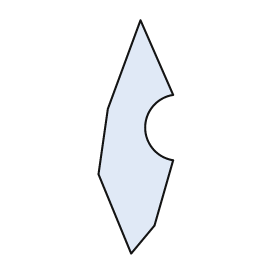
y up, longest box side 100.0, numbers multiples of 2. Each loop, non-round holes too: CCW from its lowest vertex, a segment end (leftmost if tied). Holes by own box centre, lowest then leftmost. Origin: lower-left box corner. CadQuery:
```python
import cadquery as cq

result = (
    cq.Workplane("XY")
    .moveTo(14.0, 0.0)
    .lineTo(24.0, 12.0)
    .lineTo(32.0, 40.0)
    .threePointArc((20.0, 54.0), (32.0, 68.0))
    .lineTo(18.0, 100.0)
    .lineTo(4.0, 62.0)
    .lineTo(0.0, 34.0)
    .close()
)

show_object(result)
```